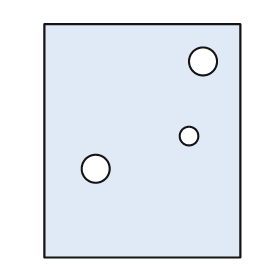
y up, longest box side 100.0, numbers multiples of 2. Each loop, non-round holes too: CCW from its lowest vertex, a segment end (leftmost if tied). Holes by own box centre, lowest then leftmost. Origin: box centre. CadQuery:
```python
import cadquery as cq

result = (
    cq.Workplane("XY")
    .moveTo(-42.0, -50.0)
    .lineTo(42.0, -50.0)
    .lineTo(42.0, 50.0)
    .lineTo(-42.0, 50.0)
    .close()
    .moveTo(-20.0, -12.0)
    .circle(6.0)
    .moveTo(20.0, 2.0)
    .circle(4.0)
    .moveTo(26.0, 34.0)
    .circle(6.0)
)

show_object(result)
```